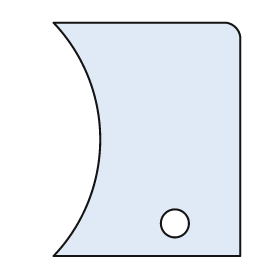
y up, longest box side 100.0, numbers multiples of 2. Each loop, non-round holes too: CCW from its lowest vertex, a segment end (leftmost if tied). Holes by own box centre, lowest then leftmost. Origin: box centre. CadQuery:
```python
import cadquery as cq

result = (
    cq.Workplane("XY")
    .moveTo(-40.0, -50.0)
    .lineTo(40.0, -50.0)
    .lineTo(40.0, 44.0)
    .threePointArc((38.0, 48.0), (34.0, 50.0))
    .lineTo(-40.0, 50.0)
    .threePointArc((-20.0, 0.0), (-40.0, -50.0))
    .close()
    .moveTo(12.0, -36.0)
    .circle(6.0)
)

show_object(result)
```